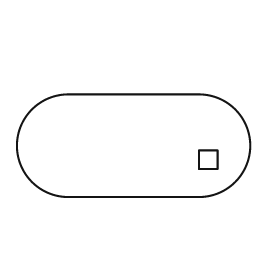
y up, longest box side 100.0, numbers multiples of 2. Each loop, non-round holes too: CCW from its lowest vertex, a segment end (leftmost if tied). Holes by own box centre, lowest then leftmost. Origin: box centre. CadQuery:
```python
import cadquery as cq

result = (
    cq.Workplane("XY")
    .moveTo(-28.0, -22.0)
    .lineTo(28.0, -22.0)
    .threePointArc((50.0, 0.0), (28.0, 22.0))
    .lineTo(-28.0, 22.0)
    .threePointArc((-50.0, 0.0), (-28.0, -22.0))
    .close()
    .moveTo(28.0, -10.0)
    .lineTo(36.0, -10.0)
    .lineTo(36.0, -2.0)
    .lineTo(28.0, -2.0)
    .close()
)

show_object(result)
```